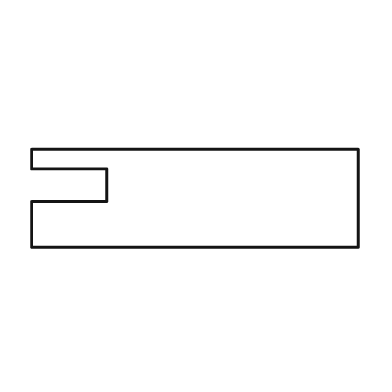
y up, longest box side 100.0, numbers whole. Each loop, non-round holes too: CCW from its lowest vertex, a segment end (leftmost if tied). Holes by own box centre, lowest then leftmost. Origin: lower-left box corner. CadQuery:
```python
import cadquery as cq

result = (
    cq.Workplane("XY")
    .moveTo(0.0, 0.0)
    .lineTo(100.0, 0.0)
    .lineTo(100.0, 30.0)
    .lineTo(0.0, 30.0)
    .lineTo(0.0, 24.0)
    .lineTo(23.0, 24.0)
    .lineTo(23.0, 14.0)
    .lineTo(0.0, 14.0)
    .close()
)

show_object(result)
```